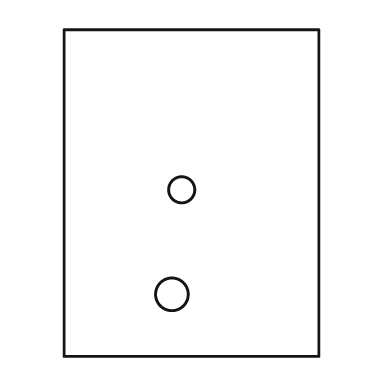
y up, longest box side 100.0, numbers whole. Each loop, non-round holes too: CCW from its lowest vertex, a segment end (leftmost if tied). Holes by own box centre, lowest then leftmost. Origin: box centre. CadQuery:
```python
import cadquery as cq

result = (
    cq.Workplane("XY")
    .moveTo(-39.0, -50.0)
    .lineTo(39.0, -50.0)
    .lineTo(39.0, 50.0)
    .lineTo(-39.0, 50.0)
    .close()
    .moveTo(-6.0, -31.0)
    .circle(5.0)
    .moveTo(-3.0, 1.0)
    .circle(4.0)
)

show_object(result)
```